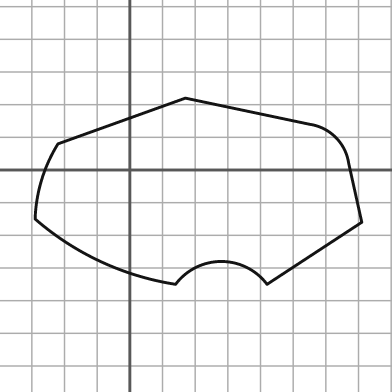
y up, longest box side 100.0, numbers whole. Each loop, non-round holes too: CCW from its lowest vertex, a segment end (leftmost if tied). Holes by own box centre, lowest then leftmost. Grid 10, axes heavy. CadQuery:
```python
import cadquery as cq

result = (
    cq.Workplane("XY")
    .moveTo(14.0, -35.0)
    .threePointArc((28.0, -28.0), (42.0, -35.0))
    .lineTo(71.0, -16.0)
    .lineTo(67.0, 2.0)
    .threePointArc((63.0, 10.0), (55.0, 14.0))
    .lineTo(17.0, 22.0)
    .lineTo(-22.0, 8.0)
    .threePointArc((-27.0, -3.0), (-29.0, -15.0))
    .threePointArc((-9.0, -28.0), (14.0, -35.0))
    .close()
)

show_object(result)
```